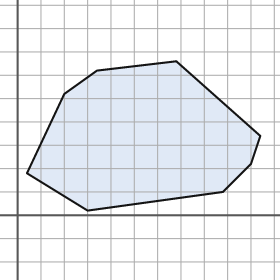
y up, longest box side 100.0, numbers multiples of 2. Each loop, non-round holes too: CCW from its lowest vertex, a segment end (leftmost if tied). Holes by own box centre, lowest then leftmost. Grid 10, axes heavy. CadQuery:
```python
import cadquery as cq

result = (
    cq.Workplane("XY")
    .moveTo(30.0, 2.0)
    .lineTo(88.0, 10.0)
    .lineTo(100.0, 22.0)
    .lineTo(104.0, 34.0)
    .lineTo(68.0, 66.0)
    .lineTo(34.0, 62.0)
    .lineTo(20.0, 52.0)
    .lineTo(4.0, 18.0)
    .close()
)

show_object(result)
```